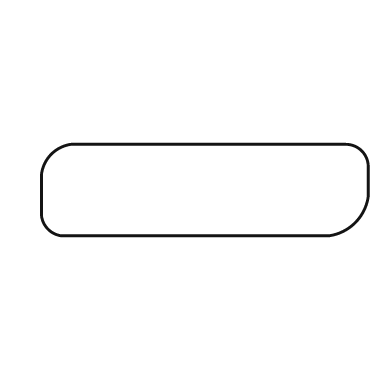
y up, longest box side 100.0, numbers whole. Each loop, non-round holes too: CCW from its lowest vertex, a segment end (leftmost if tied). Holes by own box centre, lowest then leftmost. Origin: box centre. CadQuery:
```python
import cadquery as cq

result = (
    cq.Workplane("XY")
    .moveTo(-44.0, -14.0)
    .lineTo(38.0, -14.0)
    .threePointArc((46.0, -10.0), (50.0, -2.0))
    .lineTo(50.0, 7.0)
    .threePointArc((48.0, 12.0), (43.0, 14.0))
    .lineTo(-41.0, 14.0)
    .threePointArc((-47.0, 11.0), (-50.0, 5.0))
    .lineTo(-50.0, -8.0)
    .threePointArc((-48.0, -12.0), (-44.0, -14.0))
    .close()
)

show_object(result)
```